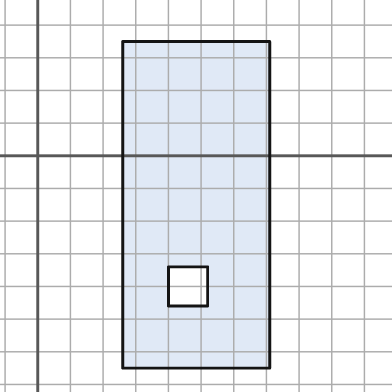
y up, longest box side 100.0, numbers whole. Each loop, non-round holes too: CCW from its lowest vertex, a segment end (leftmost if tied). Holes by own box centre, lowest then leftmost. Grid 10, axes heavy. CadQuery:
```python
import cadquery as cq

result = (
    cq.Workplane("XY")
    .moveTo(26.0, -65.0)
    .lineTo(71.0, -65.0)
    .lineTo(71.0, 35.0)
    .lineTo(26.0, 35.0)
    .close()
    .moveTo(40.0, -46.0)
    .lineTo(52.0, -46.0)
    .lineTo(52.0, -34.0)
    .lineTo(40.0, -34.0)
    .close()
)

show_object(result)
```